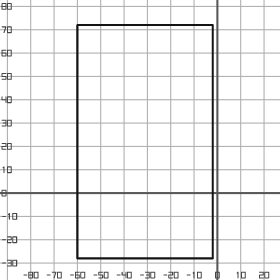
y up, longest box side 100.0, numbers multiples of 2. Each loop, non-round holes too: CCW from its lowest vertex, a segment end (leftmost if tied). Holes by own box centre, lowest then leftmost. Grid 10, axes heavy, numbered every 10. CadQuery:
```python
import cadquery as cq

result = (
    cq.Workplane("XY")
    .moveTo(-60.0, -28.0)
    .lineTo(-2.0, -28.0)
    .lineTo(-2.0, 72.0)
    .lineTo(-60.0, 72.0)
    .close()
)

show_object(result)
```